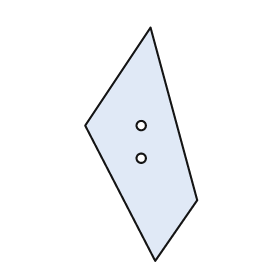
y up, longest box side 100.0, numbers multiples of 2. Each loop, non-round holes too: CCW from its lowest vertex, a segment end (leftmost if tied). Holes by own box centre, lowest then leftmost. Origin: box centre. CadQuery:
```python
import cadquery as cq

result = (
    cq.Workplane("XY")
    .moveTo(6.0, -50.0)
    .lineTo(24.0, -24.0)
    .lineTo(4.0, 50.0)
    .lineTo(-24.0, 8.0)
    .close()
    .moveTo(0.0, -6.0)
    .circle(2.0)
    .moveTo(0.0, 8.0)
    .circle(2.0)
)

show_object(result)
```